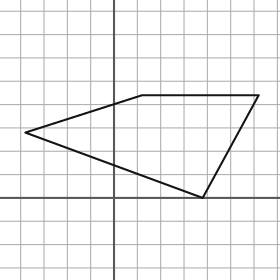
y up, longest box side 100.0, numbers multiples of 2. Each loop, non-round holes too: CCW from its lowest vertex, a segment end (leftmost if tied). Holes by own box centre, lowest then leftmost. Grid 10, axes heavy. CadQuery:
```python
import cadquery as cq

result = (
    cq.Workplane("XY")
    .moveTo(38.0, 0.0)
    .lineTo(62.0, 44.0)
    .lineTo(12.0, 44.0)
    .lineTo(-38.0, 28.0)
    .close()
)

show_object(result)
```